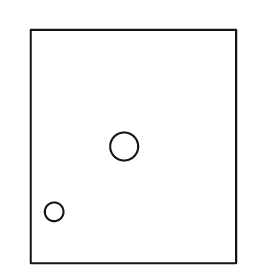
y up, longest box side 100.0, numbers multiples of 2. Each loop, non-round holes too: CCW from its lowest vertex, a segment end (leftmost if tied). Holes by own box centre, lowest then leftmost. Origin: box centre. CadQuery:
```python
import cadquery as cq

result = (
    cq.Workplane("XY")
    .moveTo(-44.0, -50.0)
    .lineTo(44.0, -50.0)
    .lineTo(44.0, 50.0)
    .lineTo(-44.0, 50.0)
    .close()
    .moveTo(-34.0, -28.0)
    .circle(4.0)
    .moveTo(-4.0, 0.0)
    .circle(6.0)
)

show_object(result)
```